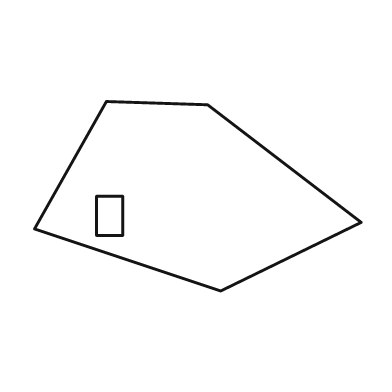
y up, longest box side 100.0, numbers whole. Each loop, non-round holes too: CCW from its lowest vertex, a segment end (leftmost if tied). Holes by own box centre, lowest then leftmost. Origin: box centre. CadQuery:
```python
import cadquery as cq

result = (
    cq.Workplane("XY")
    .moveTo(7.0, -29.0)
    .lineTo(50.0, -8.0)
    .lineTo(3.0, 28.0)
    .lineTo(-28.0, 29.0)
    .lineTo(-50.0, -10.0)
    .close()
    .moveTo(-31.0, -12.0)
    .lineTo(-23.0, -12.0)
    .lineTo(-23.0, 0.0)
    .lineTo(-31.0, 0.0)
    .close()
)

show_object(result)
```